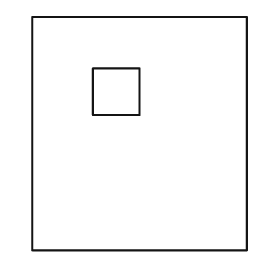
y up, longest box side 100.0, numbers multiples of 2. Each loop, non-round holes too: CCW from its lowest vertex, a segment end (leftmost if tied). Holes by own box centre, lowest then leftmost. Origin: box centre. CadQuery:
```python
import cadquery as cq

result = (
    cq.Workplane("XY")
    .moveTo(-46.0, -50.0)
    .lineTo(46.0, -50.0)
    .lineTo(46.0, 50.0)
    .lineTo(-46.0, 50.0)
    .close()
    .moveTo(-20.0, 8.0)
    .lineTo(0.0, 8.0)
    .lineTo(0.0, 28.0)
    .lineTo(-20.0, 28.0)
    .close()
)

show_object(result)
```